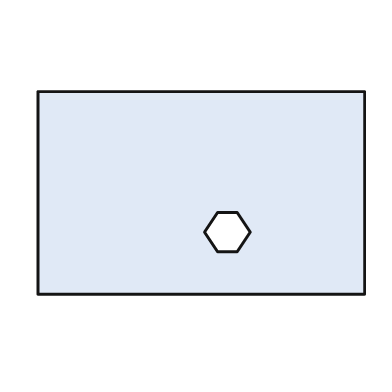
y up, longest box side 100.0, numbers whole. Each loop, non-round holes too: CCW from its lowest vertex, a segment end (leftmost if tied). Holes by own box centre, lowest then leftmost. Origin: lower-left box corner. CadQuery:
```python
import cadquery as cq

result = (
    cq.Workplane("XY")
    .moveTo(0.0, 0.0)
    .lineTo(100.0, 0.0)
    .lineTo(100.0, 62.0)
    .lineTo(0.0, 62.0)
    .close()
    .moveTo(55.0, 13.0)
    .lineTo(61.0, 13.0)
    .lineTo(65.0, 19.0)
    .lineTo(61.0, 25.0)
    .lineTo(55.0, 25.0)
    .lineTo(51.0, 19.0)
    .close()
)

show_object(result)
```